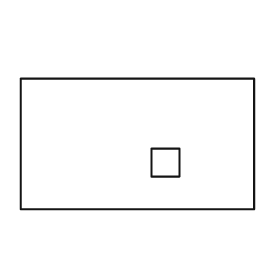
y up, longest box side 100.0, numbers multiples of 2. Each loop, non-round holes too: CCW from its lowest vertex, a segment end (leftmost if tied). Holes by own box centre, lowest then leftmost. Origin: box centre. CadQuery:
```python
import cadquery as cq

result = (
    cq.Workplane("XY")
    .moveTo(-50.0, -28.0)
    .lineTo(50.0, -28.0)
    .lineTo(50.0, 28.0)
    .lineTo(-50.0, 28.0)
    .close()
    .moveTo(6.0, -14.0)
    .lineTo(18.0, -14.0)
    .lineTo(18.0, -2.0)
    .lineTo(6.0, -2.0)
    .close()
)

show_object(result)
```